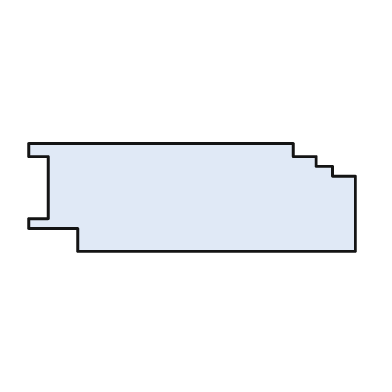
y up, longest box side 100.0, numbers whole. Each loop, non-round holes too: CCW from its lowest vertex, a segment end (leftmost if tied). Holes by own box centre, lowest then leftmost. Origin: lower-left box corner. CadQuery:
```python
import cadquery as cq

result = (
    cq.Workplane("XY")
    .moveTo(15.0, 0.0)
    .lineTo(100.0, 0.0)
    .lineTo(100.0, 23.0)
    .lineTo(93.0, 23.0)
    .lineTo(93.0, 26.0)
    .lineTo(88.0, 26.0)
    .lineTo(88.0, 29.0)
    .lineTo(81.0, 29.0)
    .lineTo(81.0, 33.0)
    .lineTo(0.0, 33.0)
    .lineTo(0.0, 29.0)
    .lineTo(6.0, 29.0)
    .lineTo(6.0, 10.0)
    .lineTo(0.0, 10.0)
    .lineTo(0.0, 7.0)
    .lineTo(15.0, 7.0)
    .close()
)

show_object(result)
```